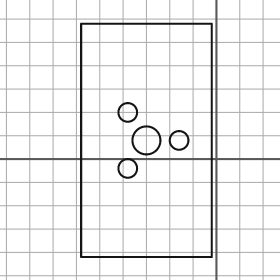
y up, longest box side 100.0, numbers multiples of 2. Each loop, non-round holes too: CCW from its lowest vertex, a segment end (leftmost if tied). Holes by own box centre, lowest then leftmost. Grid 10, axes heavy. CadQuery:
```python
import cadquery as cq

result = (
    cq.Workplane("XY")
    .moveTo(-58.0, -42.0)
    .lineTo(-2.0, -42.0)
    .lineTo(-2.0, 58.0)
    .lineTo(-58.0, 58.0)
    .close()
    .moveTo(-38.0, -4.0)
    .circle(4.0)
    .moveTo(-30.0, 8.0)
    .circle(6.0)
    .moveTo(-16.0, 8.0)
    .circle(4.0)
    .moveTo(-38.0, 20.0)
    .circle(4.0)
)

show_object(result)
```